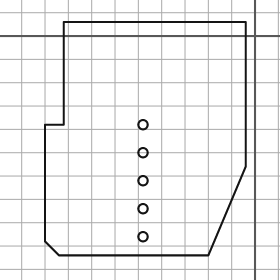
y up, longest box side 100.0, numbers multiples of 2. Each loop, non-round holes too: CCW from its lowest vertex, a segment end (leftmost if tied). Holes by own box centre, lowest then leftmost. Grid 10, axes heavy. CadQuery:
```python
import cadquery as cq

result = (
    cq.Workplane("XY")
    .moveTo(-84.0, -94.0)
    .lineTo(-20.0, -94.0)
    .lineTo(-4.0, -56.0)
    .lineTo(-4.0, 6.0)
    .lineTo(-82.0, 6.0)
    .lineTo(-82.0, -38.0)
    .lineTo(-90.0, -38.0)
    .lineTo(-90.0, -88.0)
    .close()
    .moveTo(-48.0, -86.0)
    .circle(2.0)
    .moveTo(-48.0, -74.0)
    .circle(2.0)
    .moveTo(-48.0, -62.0)
    .circle(2.0)
    .moveTo(-48.0, -50.0)
    .circle(2.0)
    .moveTo(-48.0, -38.0)
    .circle(2.0)
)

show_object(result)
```